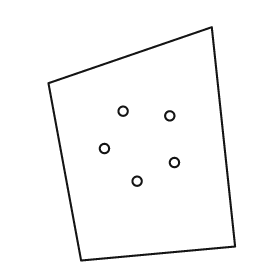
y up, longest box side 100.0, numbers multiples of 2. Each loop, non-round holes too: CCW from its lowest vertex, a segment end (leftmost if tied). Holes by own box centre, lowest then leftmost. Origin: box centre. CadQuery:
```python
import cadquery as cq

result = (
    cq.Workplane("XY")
    .moveTo(-26.0, -50.0)
    .lineTo(40.0, -44.0)
    .lineTo(30.0, 50.0)
    .lineTo(-40.0, 26.0)
    .close()
    .moveTo(-2.0, -16.0)
    .circle(2.0)
    .moveTo(14.0, -8.0)
    .circle(2.0)
    .moveTo(-16.0, -2.0)
    .circle(2.0)
    .moveTo(12.0, 12.0)
    .circle(2.0)
    .moveTo(-8.0, 14.0)
    .circle(2.0)
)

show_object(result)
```